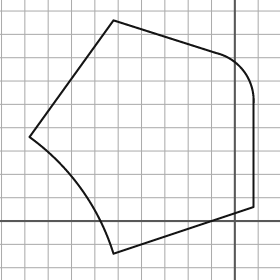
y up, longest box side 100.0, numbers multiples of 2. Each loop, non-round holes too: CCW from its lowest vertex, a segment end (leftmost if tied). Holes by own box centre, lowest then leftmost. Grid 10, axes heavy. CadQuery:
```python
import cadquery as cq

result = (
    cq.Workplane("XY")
    .moveTo(-52.0, -14.0)
    .lineTo(8.0, 6.0)
    .lineTo(8.0, 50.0)
    .threePointArc((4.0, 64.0), (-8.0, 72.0))
    .lineTo(-52.0, 86.0)
    .lineTo(-88.0, 36.0)
    .threePointArc((-66.0, 14.0), (-52.0, -14.0))
    .close()
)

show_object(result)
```